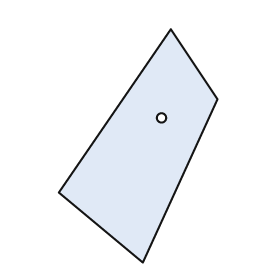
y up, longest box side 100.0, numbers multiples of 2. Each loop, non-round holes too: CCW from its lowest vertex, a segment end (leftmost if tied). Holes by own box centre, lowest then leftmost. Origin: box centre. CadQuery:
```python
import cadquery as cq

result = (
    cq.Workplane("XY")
    .moveTo(2.0, -50.0)
    .lineTo(34.0, 20.0)
    .lineTo(14.0, 50.0)
    .lineTo(-34.0, -20.0)
    .close()
    .moveTo(10.0, 12.0)
    .circle(2.0)
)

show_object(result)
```